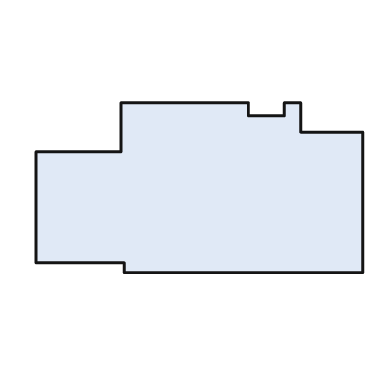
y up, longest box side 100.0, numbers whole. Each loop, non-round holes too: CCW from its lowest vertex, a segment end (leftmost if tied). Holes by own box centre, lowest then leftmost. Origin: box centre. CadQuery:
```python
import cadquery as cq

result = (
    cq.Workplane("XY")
    .moveTo(-23.0, -26.0)
    .lineTo(50.0, -26.0)
    .lineTo(50.0, 17.0)
    .lineTo(31.0, 17.0)
    .lineTo(31.0, 26.0)
    .lineTo(26.0, 26.0)
    .lineTo(26.0, 22.0)
    .lineTo(15.0, 22.0)
    .lineTo(15.0, 26.0)
    .lineTo(-24.0, 26.0)
    .lineTo(-24.0, 11.0)
    .lineTo(-50.0, 11.0)
    .lineTo(-50.0, -23.0)
    .lineTo(-23.0, -23.0)
    .close()
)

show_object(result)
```